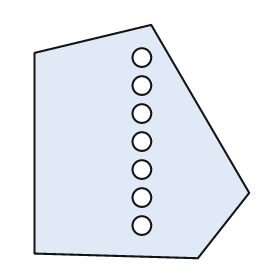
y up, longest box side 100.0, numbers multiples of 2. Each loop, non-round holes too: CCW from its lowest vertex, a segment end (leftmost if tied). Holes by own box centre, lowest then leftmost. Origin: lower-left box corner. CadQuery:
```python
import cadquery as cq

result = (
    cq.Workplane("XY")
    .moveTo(70.0, 0.0)
    .lineTo(92.0, 28.0)
    .lineTo(50.0, 100.0)
    .lineTo(0.0, 88.0)
    .lineTo(0.0, 2.0)
    .close()
    .moveTo(46.0, 14.0)
    .circle(4.0)
    .moveTo(46.0, 26.0)
    .circle(4.0)
    .moveTo(46.0, 38.0)
    .circle(4.0)
    .moveTo(46.0, 50.0)
    .circle(4.0)
    .moveTo(46.0, 62.0)
    .circle(4.0)
    .moveTo(46.0, 74.0)
    .circle(4.0)
    .moveTo(46.0, 86.0)
    .circle(4.0)
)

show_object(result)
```